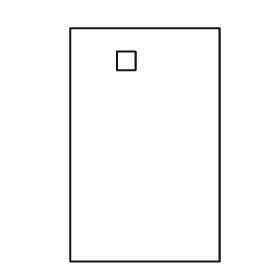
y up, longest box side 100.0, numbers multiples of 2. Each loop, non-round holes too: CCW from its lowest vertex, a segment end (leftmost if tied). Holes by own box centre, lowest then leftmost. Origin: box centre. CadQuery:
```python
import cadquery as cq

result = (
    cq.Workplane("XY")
    .moveTo(-32.0, -50.0)
    .lineTo(32.0, -50.0)
    .lineTo(32.0, 50.0)
    .lineTo(-32.0, 50.0)
    .close()
    .moveTo(-12.0, 32.0)
    .lineTo(-4.0, 32.0)
    .lineTo(-4.0, 40.0)
    .lineTo(-12.0, 40.0)
    .close()
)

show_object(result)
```